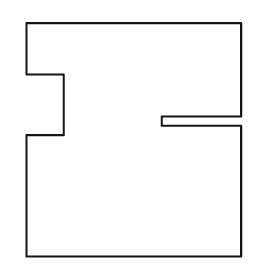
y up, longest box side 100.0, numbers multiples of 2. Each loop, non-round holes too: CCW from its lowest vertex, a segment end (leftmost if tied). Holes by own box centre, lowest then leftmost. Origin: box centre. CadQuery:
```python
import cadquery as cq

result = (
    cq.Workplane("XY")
    .moveTo(-46.0, -50.0)
    .lineTo(46.0, -50.0)
    .lineTo(46.0, 6.0)
    .lineTo(12.0, 6.0)
    .lineTo(12.0, 10.0)
    .lineTo(46.0, 10.0)
    .lineTo(46.0, 50.0)
    .lineTo(-46.0, 50.0)
    .lineTo(-46.0, 28.0)
    .lineTo(-30.0, 28.0)
    .lineTo(-30.0, 2.0)
    .lineTo(-46.0, 2.0)
    .close()
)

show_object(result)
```